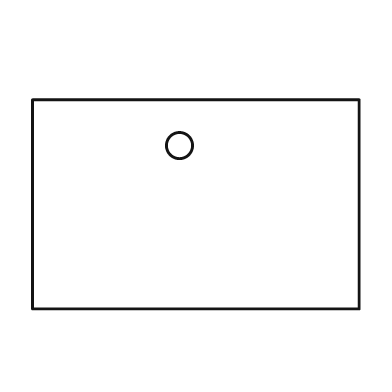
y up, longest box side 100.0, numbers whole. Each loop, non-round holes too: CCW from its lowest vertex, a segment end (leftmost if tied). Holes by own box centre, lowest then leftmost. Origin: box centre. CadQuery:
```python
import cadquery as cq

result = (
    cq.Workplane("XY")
    .moveTo(-50.0, -32.0)
    .lineTo(50.0, -32.0)
    .lineTo(50.0, 32.0)
    .lineTo(-50.0, 32.0)
    .close()
    .moveTo(-5.0, 18.0)
    .circle(4.0)
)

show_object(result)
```